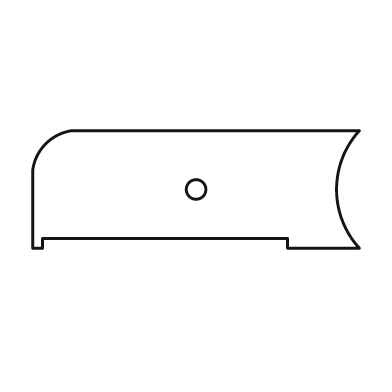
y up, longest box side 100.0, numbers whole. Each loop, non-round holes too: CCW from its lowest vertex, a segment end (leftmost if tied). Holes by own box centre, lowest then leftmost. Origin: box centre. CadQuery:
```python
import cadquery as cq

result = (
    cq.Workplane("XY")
    .moveTo(-50.0, -18.0)
    .lineTo(-47.0, -18.0)
    .lineTo(-47.0, -15.0)
    .lineTo(28.0, -15.0)
    .lineTo(28.0, -18.0)
    .lineTo(50.0, -18.0)
    .threePointArc((43.0, 0.0), (50.0, 18.0))
    .lineTo(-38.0, 18.0)
    .threePointArc((-46.0, 14.0), (-50.0, 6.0))
    .close()
    .moveTo(0.0, 0.0)
    .circle(3.0)
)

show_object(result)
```